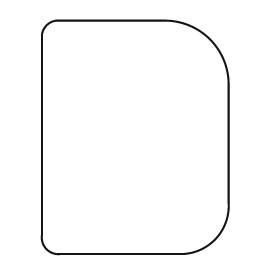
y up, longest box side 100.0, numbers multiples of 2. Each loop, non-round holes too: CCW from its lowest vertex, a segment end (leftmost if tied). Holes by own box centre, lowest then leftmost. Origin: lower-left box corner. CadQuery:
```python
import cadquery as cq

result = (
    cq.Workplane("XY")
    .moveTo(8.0, 0.0)
    .lineTo(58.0, 0.0)
    .threePointArc((74.0, 6.0), (80.0, 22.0))
    .lineTo(80.0, 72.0)
    .threePointArc((72.0, 92.0), (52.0, 100.0))
    .lineTo(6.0, 100.0)
    .threePointArc((2.0, 98.0), (0.0, 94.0))
    .lineTo(0.0, 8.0)
    .threePointArc((2.0, 2.0), (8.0, 0.0))
    .close()
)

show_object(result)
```